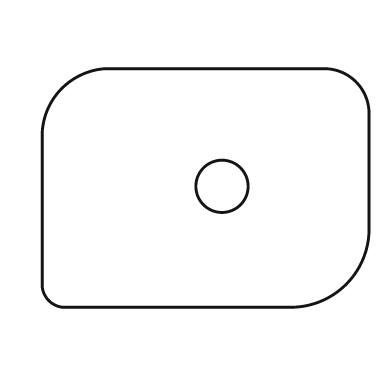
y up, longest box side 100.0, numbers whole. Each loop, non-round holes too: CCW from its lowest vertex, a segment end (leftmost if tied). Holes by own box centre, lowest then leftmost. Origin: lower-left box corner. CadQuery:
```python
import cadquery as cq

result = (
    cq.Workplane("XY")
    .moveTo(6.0, 0.0)
    .lineTo(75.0, 0.0)
    .threePointArc((93.0, 7.0), (100.0, 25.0))
    .lineTo(100.0, 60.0)
    .threePointArc((96.0, 69.0), (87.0, 73.0))
    .lineTo(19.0, 73.0)
    .threePointArc((6.0, 67.0), (0.0, 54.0))
    .lineTo(0.0, 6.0)
    .threePointArc((2.0, 2.0), (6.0, 0.0))
    .close()
    .moveTo(55.0, 37.0)
    .circle(8.0)
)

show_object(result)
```